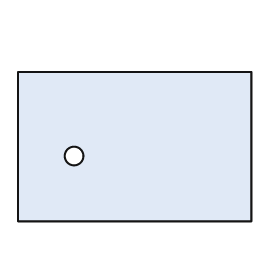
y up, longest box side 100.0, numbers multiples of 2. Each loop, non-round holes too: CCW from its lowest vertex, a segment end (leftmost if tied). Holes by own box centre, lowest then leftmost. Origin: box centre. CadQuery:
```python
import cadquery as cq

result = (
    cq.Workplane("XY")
    .moveTo(-50.0, -32.0)
    .lineTo(50.0, -32.0)
    .lineTo(50.0, 32.0)
    .lineTo(-50.0, 32.0)
    .close()
    .moveTo(-26.0, -4.0)
    .circle(4.0)
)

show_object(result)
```